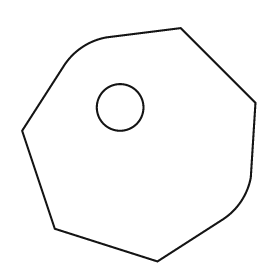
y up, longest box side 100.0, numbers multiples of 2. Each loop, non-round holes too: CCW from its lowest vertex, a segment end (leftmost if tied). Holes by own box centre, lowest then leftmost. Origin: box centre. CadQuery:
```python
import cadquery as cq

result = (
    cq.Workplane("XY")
    .moveTo(8.0, -50.0)
    .lineTo(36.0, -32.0)
    .threePointArc((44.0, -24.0), (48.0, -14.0))
    .lineTo(50.0, 18.0)
    .lineTo(18.0, 50.0)
    .lineTo(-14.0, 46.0)
    .threePointArc((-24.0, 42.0), (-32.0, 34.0))
    .lineTo(-50.0, 6.0)
    .lineTo(-36.0, -36.0)
    .close()
    .moveTo(-8.0, 16.0)
    .circle(10.0)
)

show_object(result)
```